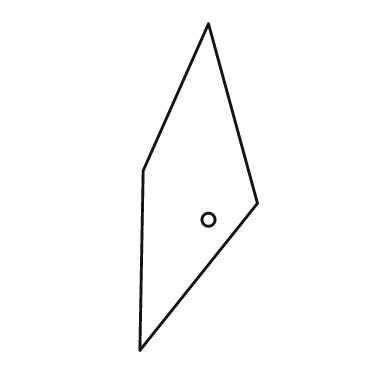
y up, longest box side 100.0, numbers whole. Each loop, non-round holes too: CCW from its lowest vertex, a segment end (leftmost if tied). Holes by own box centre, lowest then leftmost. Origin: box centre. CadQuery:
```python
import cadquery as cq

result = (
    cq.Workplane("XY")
    .moveTo(-18.0, -50.0)
    .lineTo(18.0, -5.0)
    .lineTo(3.0, 50.0)
    .lineTo(-17.0, 5.0)
    .close()
    .moveTo(3.0, -10.0)
    .circle(2.0)
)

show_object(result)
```